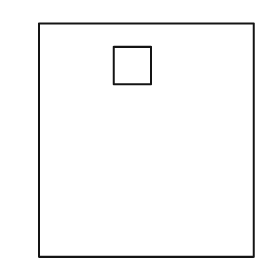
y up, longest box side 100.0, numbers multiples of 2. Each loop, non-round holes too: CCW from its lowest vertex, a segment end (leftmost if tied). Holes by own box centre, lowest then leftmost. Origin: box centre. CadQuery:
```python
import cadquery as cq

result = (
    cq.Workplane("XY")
    .moveTo(-46.0, -50.0)
    .lineTo(46.0, -50.0)
    .lineTo(46.0, 50.0)
    .lineTo(-46.0, 50.0)
    .close()
    .moveTo(-14.0, 24.0)
    .lineTo(2.0, 24.0)
    .lineTo(2.0, 40.0)
    .lineTo(-14.0, 40.0)
    .close()
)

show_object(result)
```